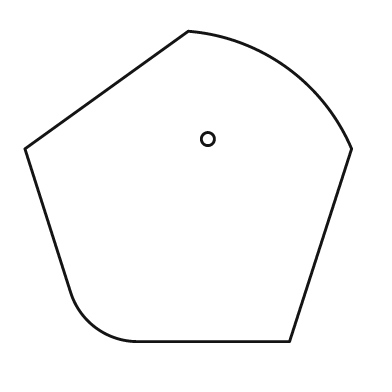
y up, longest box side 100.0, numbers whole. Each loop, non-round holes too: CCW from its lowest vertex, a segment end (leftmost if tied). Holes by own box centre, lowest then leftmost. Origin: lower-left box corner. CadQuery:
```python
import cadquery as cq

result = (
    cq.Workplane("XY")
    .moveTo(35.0, 0.0)
    .lineTo(81.0, 0.0)
    .lineTo(100.0, 59.0)
    .threePointArc((80.0, 84.0), (50.0, 95.0))
    .lineTo(0.0, 59.0)
    .lineTo(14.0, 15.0)
    .threePointArc((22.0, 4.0), (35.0, 0.0))
    .close()
    .moveTo(56.0, 62.0)
    .circle(2.0)
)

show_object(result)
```